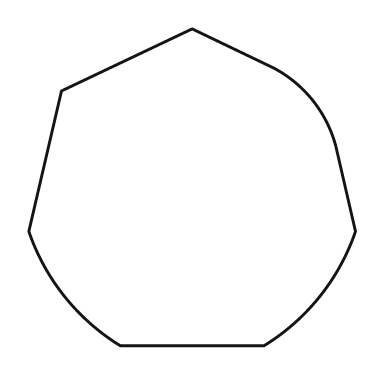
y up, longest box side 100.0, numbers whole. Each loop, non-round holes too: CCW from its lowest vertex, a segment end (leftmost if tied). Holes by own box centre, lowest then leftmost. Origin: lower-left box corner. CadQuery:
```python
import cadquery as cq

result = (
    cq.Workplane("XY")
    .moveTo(28.0, 0.0)
    .lineTo(72.0, 0.0)
    .threePointArc((89.0, 15.0), (100.0, 35.0))
    .lineTo(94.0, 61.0)
    .threePointArc((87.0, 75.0), (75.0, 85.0))
    .lineTo(50.0, 97.0)
    .lineTo(10.0, 78.0)
    .lineTo(0.0, 35.0)
    .threePointArc((11.0, 15.0), (28.0, 0.0))
    .close()
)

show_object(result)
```